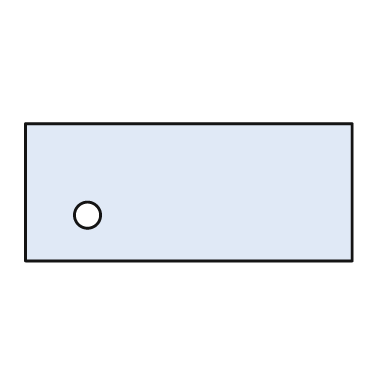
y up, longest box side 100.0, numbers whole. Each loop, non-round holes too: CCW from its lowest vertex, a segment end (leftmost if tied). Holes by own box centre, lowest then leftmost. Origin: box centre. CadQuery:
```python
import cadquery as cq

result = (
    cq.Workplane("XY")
    .moveTo(-50.0, -21.0)
    .lineTo(50.0, -21.0)
    .lineTo(50.0, 21.0)
    .lineTo(-50.0, 21.0)
    .close()
    .moveTo(-31.0, -7.0)
    .circle(4.0)
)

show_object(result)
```